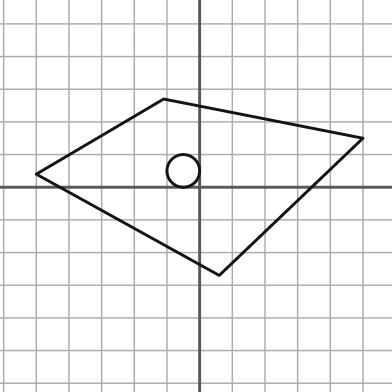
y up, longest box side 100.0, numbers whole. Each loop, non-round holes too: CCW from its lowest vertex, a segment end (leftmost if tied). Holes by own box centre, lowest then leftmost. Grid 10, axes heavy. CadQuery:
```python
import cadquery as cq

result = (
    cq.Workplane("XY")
    .moveTo(6.0, -27.0)
    .lineTo(50.0, 15.0)
    .lineTo(-11.0, 27.0)
    .lineTo(-50.0, 4.0)
    .close()
    .moveTo(-5.0, 5.0)
    .circle(5.0)
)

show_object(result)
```